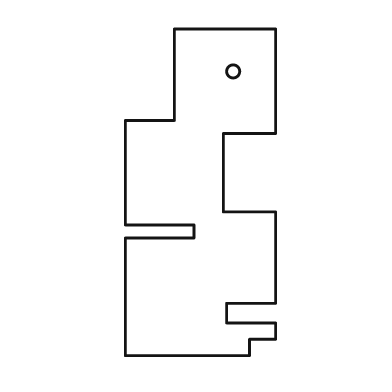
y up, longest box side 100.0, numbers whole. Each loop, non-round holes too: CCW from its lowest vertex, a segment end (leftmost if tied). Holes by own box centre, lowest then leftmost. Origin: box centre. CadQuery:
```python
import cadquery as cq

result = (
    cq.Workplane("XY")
    .moveTo(-23.0, -50.0)
    .lineTo(15.0, -50.0)
    .lineTo(15.0, -45.0)
    .lineTo(23.0, -45.0)
    .lineTo(23.0, -40.0)
    .lineTo(8.0, -40.0)
    .lineTo(8.0, -34.0)
    .lineTo(23.0, -34.0)
    .lineTo(23.0, -6.0)
    .lineTo(7.0, -6.0)
    .lineTo(7.0, 18.0)
    .lineTo(23.0, 18.0)
    .lineTo(23.0, 50.0)
    .lineTo(-8.0, 50.0)
    .lineTo(-8.0, 22.0)
    .lineTo(-23.0, 22.0)
    .lineTo(-23.0, -10.0)
    .lineTo(-2.0, -10.0)
    .lineTo(-2.0, -14.0)
    .lineTo(-23.0, -14.0)
    .close()
    .moveTo(10.0, 37.0)
    .circle(2.0)
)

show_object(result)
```